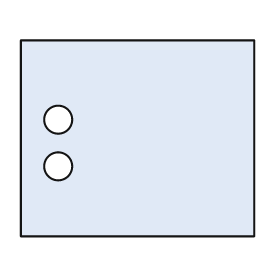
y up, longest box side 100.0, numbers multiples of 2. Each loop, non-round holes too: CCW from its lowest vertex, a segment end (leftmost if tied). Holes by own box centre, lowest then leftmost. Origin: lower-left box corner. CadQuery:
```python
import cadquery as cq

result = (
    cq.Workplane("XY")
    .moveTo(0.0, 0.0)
    .lineTo(100.0, 0.0)
    .lineTo(100.0, 84.0)
    .lineTo(0.0, 84.0)
    .close()
    .moveTo(16.0, 30.0)
    .circle(6.0)
    .moveTo(16.0, 50.0)
    .circle(6.0)
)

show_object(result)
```